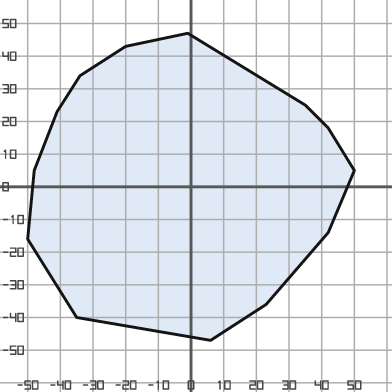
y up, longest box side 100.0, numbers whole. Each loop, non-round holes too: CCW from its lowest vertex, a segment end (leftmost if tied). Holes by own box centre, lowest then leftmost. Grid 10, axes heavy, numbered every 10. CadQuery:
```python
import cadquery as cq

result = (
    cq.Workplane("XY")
    .moveTo(6.0, -47.0)
    .lineTo(23.0, -36.0)
    .lineTo(42.0, -14.0)
    .lineTo(50.0, 5.0)
    .lineTo(42.0, 18.0)
    .lineTo(35.0, 25.0)
    .lineTo(-1.0, 47.0)
    .lineTo(-20.0, 43.0)
    .lineTo(-34.0, 34.0)
    .lineTo(-41.0, 23.0)
    .lineTo(-48.0, 5.0)
    .lineTo(-50.0, -16.0)
    .lineTo(-35.0, -40.0)
    .close()
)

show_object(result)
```